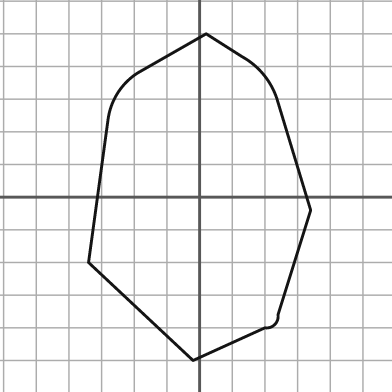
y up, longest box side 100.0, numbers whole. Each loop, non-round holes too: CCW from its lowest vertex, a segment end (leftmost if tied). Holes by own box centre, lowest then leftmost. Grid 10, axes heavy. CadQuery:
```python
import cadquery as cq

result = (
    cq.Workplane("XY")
    .moveTo(-2.0, -50.0)
    .lineTo(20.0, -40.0)
    .threePointArc((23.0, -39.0), (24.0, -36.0))
    .lineTo(34.0, -4.0)
    .lineTo(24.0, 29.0)
    .threePointArc((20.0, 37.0), (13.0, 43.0))
    .lineTo(2.0, 50.0)
    .lineTo(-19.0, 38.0)
    .threePointArc((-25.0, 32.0), (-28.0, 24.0))
    .lineTo(-34.0, -20.0)
    .close()
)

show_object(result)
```